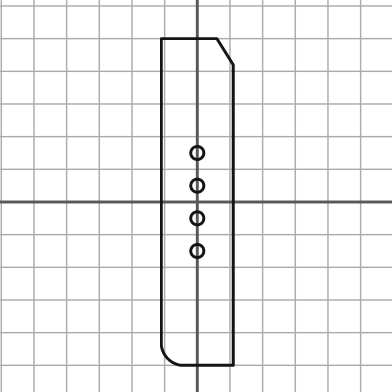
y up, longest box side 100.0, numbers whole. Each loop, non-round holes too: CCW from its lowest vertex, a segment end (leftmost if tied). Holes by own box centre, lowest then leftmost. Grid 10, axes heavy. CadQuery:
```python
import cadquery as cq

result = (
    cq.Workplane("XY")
    .moveTo(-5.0, -50.0)
    .lineTo(11.0, -50.0)
    .lineTo(11.0, 42.0)
    .lineTo(6.0, 50.0)
    .lineTo(-11.0, 50.0)
    .lineTo(-11.0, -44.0)
    .threePointArc((-9.0, -48.0), (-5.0, -50.0))
    .close()
    .moveTo(0.0, -15.0)
    .circle(2.0)
    .moveTo(0.0, -5.0)
    .circle(2.0)
    .moveTo(0.0, 5.0)
    .circle(2.0)
    .moveTo(0.0, 15.0)
    .circle(2.0)
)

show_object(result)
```